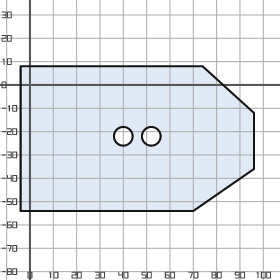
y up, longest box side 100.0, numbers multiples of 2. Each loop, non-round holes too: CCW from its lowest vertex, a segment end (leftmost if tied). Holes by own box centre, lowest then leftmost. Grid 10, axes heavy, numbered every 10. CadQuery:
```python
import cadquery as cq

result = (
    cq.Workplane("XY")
    .moveTo(-4.0, -54.0)
    .lineTo(70.0, -54.0)
    .lineTo(96.0, -36.0)
    .lineTo(96.0, -12.0)
    .lineTo(74.0, 8.0)
    .lineTo(-4.0, 8.0)
    .close()
    .moveTo(40.0, -22.0)
    .circle(4.0)
    .moveTo(52.0, -22.0)
    .circle(4.0)
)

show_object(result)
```